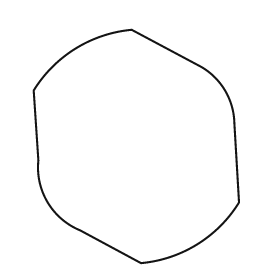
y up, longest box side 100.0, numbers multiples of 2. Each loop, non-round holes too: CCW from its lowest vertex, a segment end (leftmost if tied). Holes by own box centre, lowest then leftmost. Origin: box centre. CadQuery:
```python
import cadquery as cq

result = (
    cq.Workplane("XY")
    .moveTo(2.0, -50.0)
    .threePointArc((26.0, -42.0), (44.0, -24.0))
    .lineTo(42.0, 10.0)
    .threePointArc((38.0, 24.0), (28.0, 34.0))
    .lineTo(-2.0, 50.0)
    .threePointArc((-26.0, 42.0), (-44.0, 24.0))
    .lineTo(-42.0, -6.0)
    .threePointArc((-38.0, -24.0), (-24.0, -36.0))
    .close()
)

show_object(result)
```